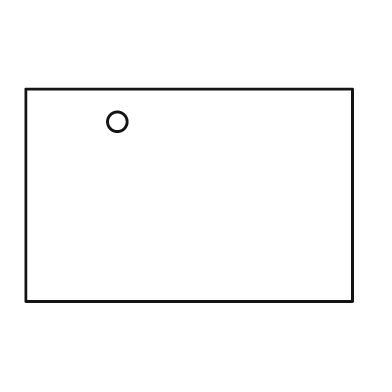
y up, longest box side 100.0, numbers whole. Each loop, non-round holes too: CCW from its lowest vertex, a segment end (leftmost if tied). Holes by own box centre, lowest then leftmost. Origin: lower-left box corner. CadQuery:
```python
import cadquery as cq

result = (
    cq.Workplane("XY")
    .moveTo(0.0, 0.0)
    .lineTo(100.0, 0.0)
    .lineTo(100.0, 65.0)
    .lineTo(0.0, 65.0)
    .close()
    .moveTo(28.0, 55.0)
    .circle(3.0)
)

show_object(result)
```